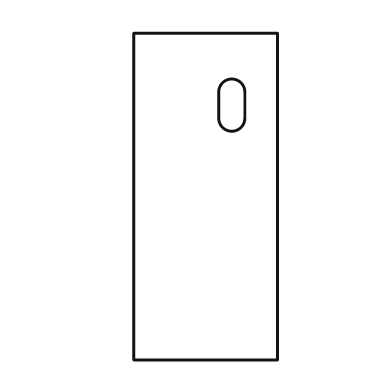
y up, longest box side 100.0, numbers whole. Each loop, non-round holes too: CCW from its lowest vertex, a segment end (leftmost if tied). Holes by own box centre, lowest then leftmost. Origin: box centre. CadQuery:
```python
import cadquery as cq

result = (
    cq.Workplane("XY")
    .moveTo(-22.0, -50.0)
    .lineTo(22.0, -50.0)
    .lineTo(22.0, 50.0)
    .lineTo(-22.0, 50.0)
    .close()
    .moveTo(4.0, 24.0)
    .threePointArc((8.0, 20.0), (12.0, 24.0))
    .lineTo(12.0, 32.0)
    .threePointArc((8.0, 36.0), (4.0, 32.0))
    .close()
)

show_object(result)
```